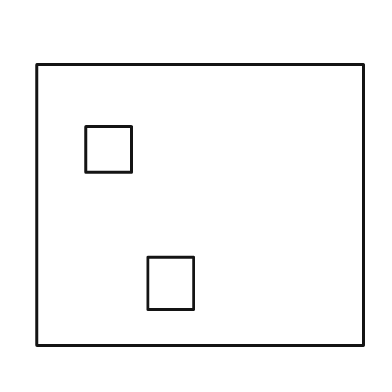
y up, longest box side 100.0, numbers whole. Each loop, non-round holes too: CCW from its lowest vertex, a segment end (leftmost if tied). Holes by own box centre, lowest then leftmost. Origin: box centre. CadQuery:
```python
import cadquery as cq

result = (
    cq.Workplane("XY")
    .moveTo(-50.0, -43.0)
    .lineTo(50.0, -43.0)
    .lineTo(50.0, 43.0)
    .lineTo(-50.0, 43.0)
    .close()
    .moveTo(-16.0, -32.0)
    .lineTo(-2.0, -32.0)
    .lineTo(-2.0, -16.0)
    .lineTo(-16.0, -16.0)
    .close()
    .moveTo(-35.0, 10.0)
    .lineTo(-21.0, 10.0)
    .lineTo(-21.0, 24.0)
    .lineTo(-35.0, 24.0)
    .close()
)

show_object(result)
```